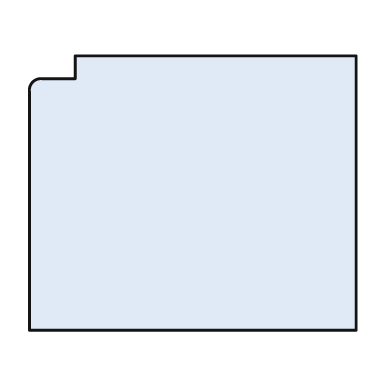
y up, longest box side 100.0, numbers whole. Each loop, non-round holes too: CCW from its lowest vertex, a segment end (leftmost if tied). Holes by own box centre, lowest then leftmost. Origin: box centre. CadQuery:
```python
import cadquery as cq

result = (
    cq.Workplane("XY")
    .moveTo(-50.0, -42.0)
    .lineTo(50.0, -42.0)
    .lineTo(50.0, 42.0)
    .lineTo(-36.0, 42.0)
    .lineTo(-36.0, 35.0)
    .lineTo(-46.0, 35.0)
    .threePointArc((-49.0, 34.0), (-50.0, 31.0))
    .close()
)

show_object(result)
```